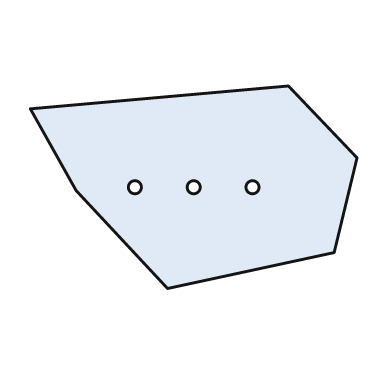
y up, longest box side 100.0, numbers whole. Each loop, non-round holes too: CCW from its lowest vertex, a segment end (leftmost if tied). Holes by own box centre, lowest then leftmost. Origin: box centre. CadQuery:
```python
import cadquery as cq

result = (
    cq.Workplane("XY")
    .moveTo(-8.0, -31.0)
    .lineTo(43.0, -20.0)
    .lineTo(50.0, 9.0)
    .lineTo(29.0, 31.0)
    .lineTo(-50.0, 24.0)
    .lineTo(-36.0, -1.0)
    .close()
    .moveTo(-18.0, 0.0)
    .circle(2.0)
    .moveTo(0.0, 0.0)
    .circle(2.0)
    .moveTo(18.0, 0.0)
    .circle(2.0)
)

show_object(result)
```